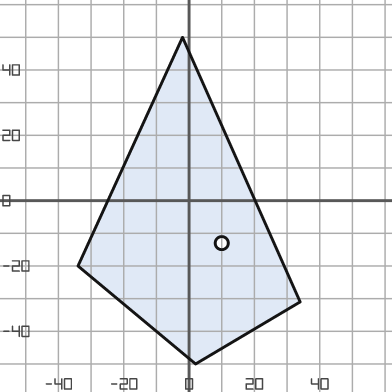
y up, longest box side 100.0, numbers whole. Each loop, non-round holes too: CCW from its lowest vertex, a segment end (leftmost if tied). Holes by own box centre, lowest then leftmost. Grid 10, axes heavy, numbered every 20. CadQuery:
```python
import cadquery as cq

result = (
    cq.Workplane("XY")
    .moveTo(2.0, -50.0)
    .lineTo(34.0, -31.0)
    .lineTo(-2.0, 50.0)
    .lineTo(-34.0, -20.0)
    .close()
    .moveTo(10.0, -13.0)
    .circle(2.0)
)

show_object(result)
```